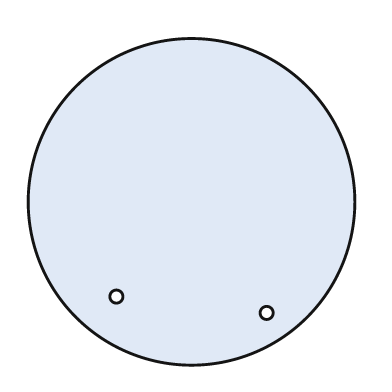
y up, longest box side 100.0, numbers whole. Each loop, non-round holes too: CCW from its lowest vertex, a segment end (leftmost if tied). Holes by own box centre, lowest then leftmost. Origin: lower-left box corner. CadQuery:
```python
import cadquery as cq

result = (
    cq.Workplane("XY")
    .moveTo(50.0, 50.0)
    .circle(50.0)
    .moveTo(73.0, 16.0)
    .circle(2.0)
    .moveTo(27.0, 21.0)
    .circle(2.0)
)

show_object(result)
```